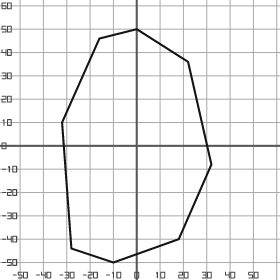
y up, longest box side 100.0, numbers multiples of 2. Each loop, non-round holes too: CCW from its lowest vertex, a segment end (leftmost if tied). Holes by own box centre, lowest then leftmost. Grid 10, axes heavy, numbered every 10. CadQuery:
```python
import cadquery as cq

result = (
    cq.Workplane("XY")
    .moveTo(-10.0, -50.0)
    .lineTo(18.0, -40.0)
    .lineTo(32.0, -8.0)
    .lineTo(22.0, 36.0)
    .lineTo(0.0, 50.0)
    .lineTo(-16.0, 46.0)
    .lineTo(-32.0, 10.0)
    .lineTo(-28.0, -44.0)
    .close()
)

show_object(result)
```